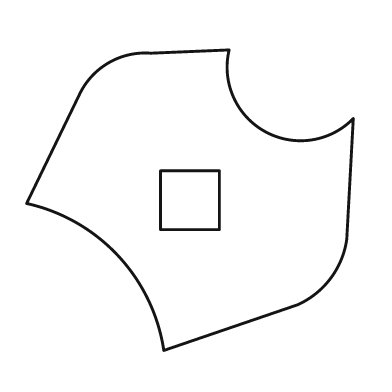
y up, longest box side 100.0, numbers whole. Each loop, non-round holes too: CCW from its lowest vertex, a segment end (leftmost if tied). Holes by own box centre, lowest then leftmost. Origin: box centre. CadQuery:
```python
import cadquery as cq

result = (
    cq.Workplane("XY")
    .moveTo(-8.0, -46.0)
    .lineTo(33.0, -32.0)
    .threePointArc((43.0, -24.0), (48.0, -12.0))
    .lineTo(50.0, 25.0)
    .threePointArc((23.0, 21.0), (12.0, 46.0))
    .lineTo(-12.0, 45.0)
    .threePointArc((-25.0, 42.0), (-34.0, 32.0))
    .lineTo(-50.0, -1.0)
    .threePointArc((-22.0, -17.0), (-8.0, -46.0))
    .close()
    .moveTo(-9.0, -9.0)
    .lineTo(9.0, -9.0)
    .lineTo(9.0, 9.0)
    .lineTo(-9.0, 9.0)
    .close()
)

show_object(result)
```